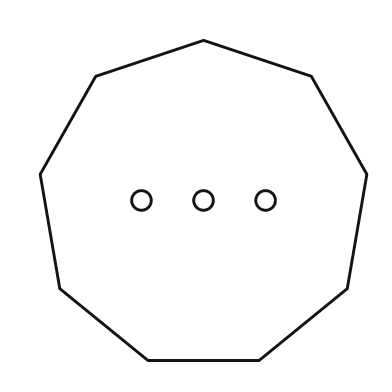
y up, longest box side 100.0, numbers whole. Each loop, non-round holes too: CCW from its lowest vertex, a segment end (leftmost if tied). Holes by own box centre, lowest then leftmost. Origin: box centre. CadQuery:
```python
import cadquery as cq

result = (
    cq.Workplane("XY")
    .moveTo(-17.0, -49.0)
    .lineTo(17.0, -49.0)
    .lineTo(44.0, -27.0)
    .lineTo(50.0, 8.0)
    .lineTo(33.0, 38.0)
    .lineTo(0.0, 49.0)
    .lineTo(-33.0, 38.0)
    .lineTo(-50.0, 8.0)
    .lineTo(-44.0, -27.0)
    .close()
    .moveTo(-19.0, 0.0)
    .circle(3.0)
    .moveTo(0.0, 0.0)
    .circle(3.0)
    .moveTo(19.0, 0.0)
    .circle(3.0)
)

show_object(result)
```